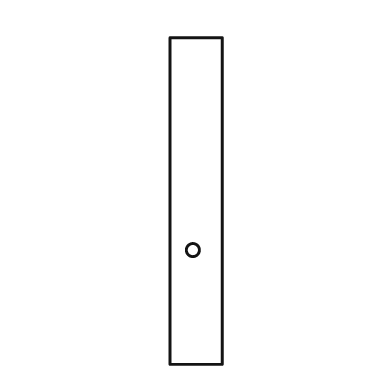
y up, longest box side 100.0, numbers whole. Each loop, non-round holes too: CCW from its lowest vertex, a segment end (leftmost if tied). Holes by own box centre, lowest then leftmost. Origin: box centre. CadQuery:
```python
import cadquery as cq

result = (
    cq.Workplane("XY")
    .moveTo(-8.0, -50.0)
    .lineTo(8.0, -50.0)
    .lineTo(8.0, 50.0)
    .lineTo(-8.0, 50.0)
    .close()
    .moveTo(-1.0, -15.0)
    .circle(2.0)
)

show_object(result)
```